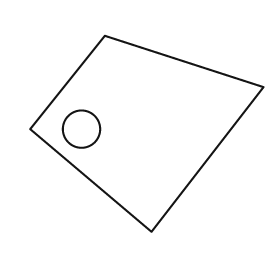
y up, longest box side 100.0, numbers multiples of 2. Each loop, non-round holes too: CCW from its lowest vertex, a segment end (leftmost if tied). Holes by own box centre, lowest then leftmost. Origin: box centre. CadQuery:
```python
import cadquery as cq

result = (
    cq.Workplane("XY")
    .moveTo(2.0, -42.0)
    .lineTo(50.0, 20.0)
    .lineTo(-18.0, 42.0)
    .lineTo(-50.0, 2.0)
    .close()
    .moveTo(-28.0, 2.0)
    .circle(8.0)
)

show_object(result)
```